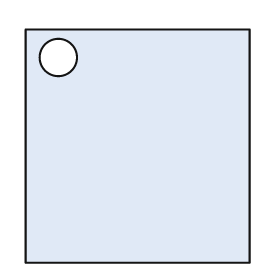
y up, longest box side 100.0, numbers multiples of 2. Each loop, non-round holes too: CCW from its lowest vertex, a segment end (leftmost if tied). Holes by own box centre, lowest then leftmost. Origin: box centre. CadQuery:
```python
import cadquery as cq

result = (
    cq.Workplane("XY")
    .moveTo(-48.0, -50.0)
    .lineTo(48.0, -50.0)
    .lineTo(48.0, 50.0)
    .lineTo(-48.0, 50.0)
    .close()
    .moveTo(-34.0, 38.0)
    .circle(8.0)
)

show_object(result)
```